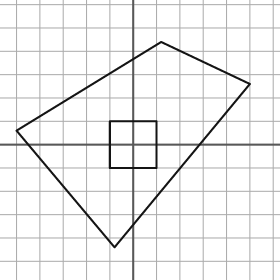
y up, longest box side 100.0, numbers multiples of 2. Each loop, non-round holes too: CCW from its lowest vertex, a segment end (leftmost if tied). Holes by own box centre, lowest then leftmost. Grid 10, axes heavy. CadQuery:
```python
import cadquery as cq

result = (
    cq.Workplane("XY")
    .moveTo(-8.0, -44.0)
    .lineTo(50.0, 26.0)
    .lineTo(12.0, 44.0)
    .lineTo(-50.0, 6.0)
    .close()
    .moveTo(-10.0, -10.0)
    .lineTo(10.0, -10.0)
    .lineTo(10.0, 10.0)
    .lineTo(-10.0, 10.0)
    .close()
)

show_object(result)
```